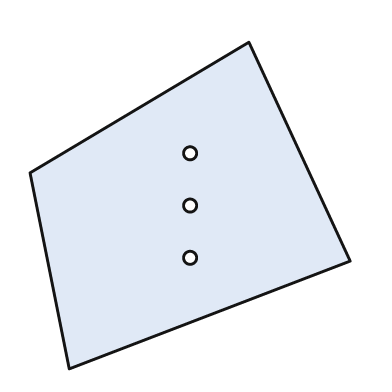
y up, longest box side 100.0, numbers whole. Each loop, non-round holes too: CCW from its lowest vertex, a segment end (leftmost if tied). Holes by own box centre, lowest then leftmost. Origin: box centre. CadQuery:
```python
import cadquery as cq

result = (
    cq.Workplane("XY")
    .moveTo(-37.0, -50.0)
    .lineTo(49.0, -17.0)
    .lineTo(18.0, 50.0)
    .lineTo(-49.0, 10.0)
    .close()
    .moveTo(0.0, -16.0)
    .circle(2.0)
    .moveTo(0.0, 0.0)
    .circle(2.0)
    .moveTo(0.0, 16.0)
    .circle(2.0)
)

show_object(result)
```